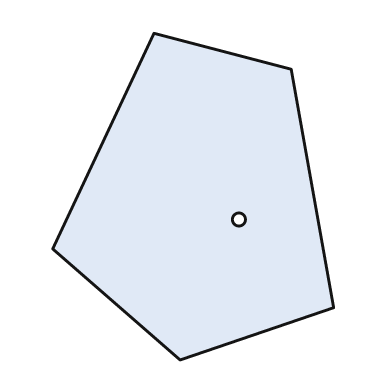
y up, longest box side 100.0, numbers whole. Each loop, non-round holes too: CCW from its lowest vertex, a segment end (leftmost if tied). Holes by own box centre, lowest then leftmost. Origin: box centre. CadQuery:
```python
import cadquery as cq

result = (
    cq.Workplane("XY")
    .moveTo(-4.0, -50.0)
    .lineTo(43.0, -34.0)
    .lineTo(30.0, 39.0)
    .lineTo(-12.0, 50.0)
    .lineTo(-43.0, -16.0)
    .close()
    .moveTo(14.0, -7.0)
    .circle(2.0)
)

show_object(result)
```